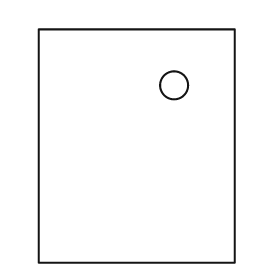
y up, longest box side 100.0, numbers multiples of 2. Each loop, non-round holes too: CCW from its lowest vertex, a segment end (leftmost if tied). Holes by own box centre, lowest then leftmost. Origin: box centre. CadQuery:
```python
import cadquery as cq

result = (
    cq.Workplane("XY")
    .moveTo(-42.0, -50.0)
    .lineTo(42.0, -50.0)
    .lineTo(42.0, 50.0)
    .lineTo(-42.0, 50.0)
    .close()
    .moveTo(16.0, 26.0)
    .circle(6.0)
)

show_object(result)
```